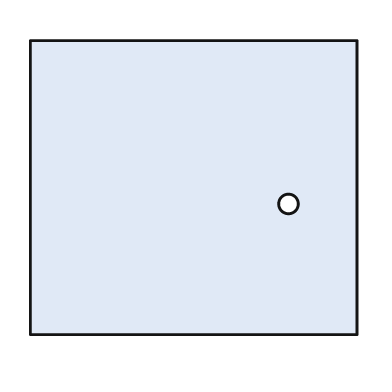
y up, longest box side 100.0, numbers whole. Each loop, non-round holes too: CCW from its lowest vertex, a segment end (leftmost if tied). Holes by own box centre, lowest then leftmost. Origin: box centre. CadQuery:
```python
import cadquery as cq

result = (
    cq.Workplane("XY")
    .moveTo(-50.0, -45.0)
    .lineTo(50.0, -45.0)
    .lineTo(50.0, 45.0)
    .lineTo(-50.0, 45.0)
    .close()
    .moveTo(29.0, -5.0)
    .circle(3.0)
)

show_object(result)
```